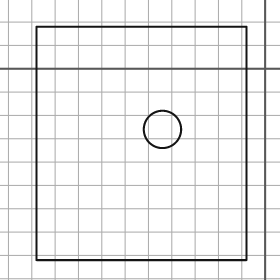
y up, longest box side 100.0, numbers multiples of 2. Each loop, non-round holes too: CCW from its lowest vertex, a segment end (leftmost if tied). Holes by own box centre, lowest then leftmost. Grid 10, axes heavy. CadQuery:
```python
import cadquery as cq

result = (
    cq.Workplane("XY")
    .moveTo(-98.0, -82.0)
    .lineTo(-8.0, -82.0)
    .lineTo(-8.0, 18.0)
    .lineTo(-98.0, 18.0)
    .close()
    .moveTo(-44.0, -26.0)
    .circle(8.0)
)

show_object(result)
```